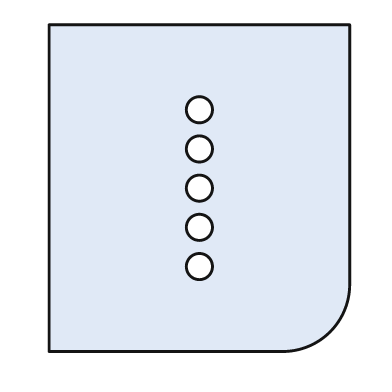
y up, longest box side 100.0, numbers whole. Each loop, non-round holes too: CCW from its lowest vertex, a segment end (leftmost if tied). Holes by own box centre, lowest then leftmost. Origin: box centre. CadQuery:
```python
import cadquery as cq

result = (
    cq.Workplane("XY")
    .moveTo(-46.0, -50.0)
    .lineTo(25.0, -50.0)
    .threePointArc((40.0, -44.0), (46.0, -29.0))
    .lineTo(46.0, 50.0)
    .lineTo(-46.0, 50.0)
    .close()
    .moveTo(0.0, -24.0)
    .circle(4.0)
    .moveTo(0.0, -12.0)
    .circle(4.0)
    .moveTo(0.0, 0.0)
    .circle(4.0)
    .moveTo(0.0, 12.0)
    .circle(4.0)
    .moveTo(0.0, 24.0)
    .circle(4.0)
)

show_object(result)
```